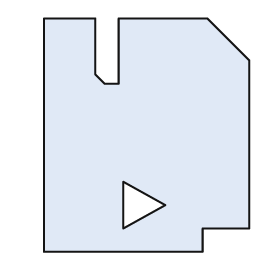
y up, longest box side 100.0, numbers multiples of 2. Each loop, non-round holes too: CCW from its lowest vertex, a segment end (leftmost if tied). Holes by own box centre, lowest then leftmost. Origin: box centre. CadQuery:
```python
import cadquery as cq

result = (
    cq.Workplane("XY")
    .moveTo(-44.0, -50.0)
    .lineTo(24.0, -50.0)
    .lineTo(24.0, -40.0)
    .lineTo(44.0, -40.0)
    .lineTo(44.0, 32.0)
    .lineTo(26.0, 50.0)
    .lineTo(-12.0, 50.0)
    .lineTo(-12.0, 22.0)
    .lineTo(-18.0, 22.0)
    .lineTo(-22.0, 26.0)
    .lineTo(-22.0, 50.0)
    .lineTo(-44.0, 50.0)
    .close()
    .moveTo(-10.0, -40.0)
    .lineTo(8.0, -30.0)
    .lineTo(-10.0, -20.0)
    .close()
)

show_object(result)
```